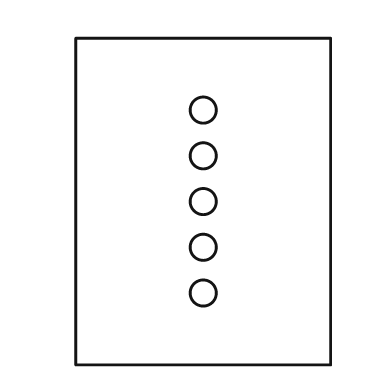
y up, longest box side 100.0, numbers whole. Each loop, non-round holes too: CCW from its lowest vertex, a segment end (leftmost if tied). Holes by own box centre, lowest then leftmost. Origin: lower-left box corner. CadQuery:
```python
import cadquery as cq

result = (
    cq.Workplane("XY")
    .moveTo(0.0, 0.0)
    .lineTo(78.0, 0.0)
    .lineTo(78.0, 100.0)
    .lineTo(0.0, 100.0)
    .close()
    .moveTo(39.0, 22.0)
    .circle(4.0)
    .moveTo(39.0, 36.0)
    .circle(4.0)
    .moveTo(39.0, 50.0)
    .circle(4.0)
    .moveTo(39.0, 64.0)
    .circle(4.0)
    .moveTo(39.0, 78.0)
    .circle(4.0)
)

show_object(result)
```